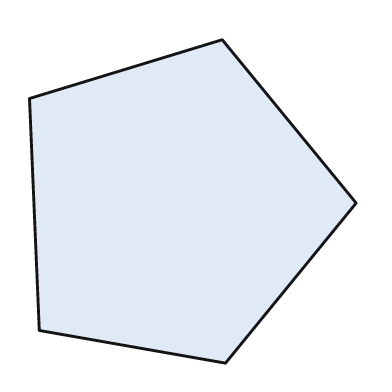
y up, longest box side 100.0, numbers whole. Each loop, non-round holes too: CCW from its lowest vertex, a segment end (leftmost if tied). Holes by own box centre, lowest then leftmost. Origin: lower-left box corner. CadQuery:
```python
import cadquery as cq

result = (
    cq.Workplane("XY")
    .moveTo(60.0, 0.0)
    .lineTo(100.0, 49.0)
    .lineTo(59.0, 99.0)
    .lineTo(0.0, 81.0)
    .lineTo(3.0, 10.0)
    .close()
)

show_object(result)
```